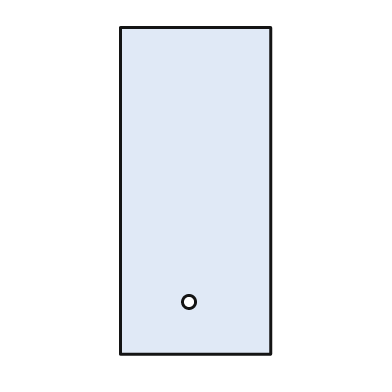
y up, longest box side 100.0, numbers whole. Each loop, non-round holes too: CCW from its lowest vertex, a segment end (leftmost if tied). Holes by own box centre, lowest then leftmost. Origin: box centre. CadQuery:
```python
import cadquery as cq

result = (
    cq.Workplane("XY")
    .moveTo(-23.0, -50.0)
    .lineTo(23.0, -50.0)
    .lineTo(23.0, 50.0)
    .lineTo(-23.0, 50.0)
    .close()
    .moveTo(-2.0, -34.0)
    .circle(2.0)
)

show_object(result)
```